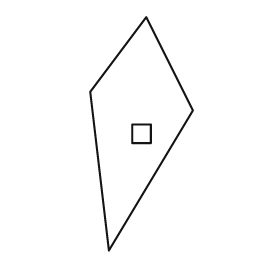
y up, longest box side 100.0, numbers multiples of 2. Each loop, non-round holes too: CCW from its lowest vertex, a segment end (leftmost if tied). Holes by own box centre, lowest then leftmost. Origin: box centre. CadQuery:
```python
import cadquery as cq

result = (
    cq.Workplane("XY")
    .moveTo(-14.0, -50.0)
    .lineTo(22.0, 10.0)
    .lineTo(2.0, 50.0)
    .lineTo(-22.0, 18.0)
    .close()
    .moveTo(-4.0, -4.0)
    .lineTo(4.0, -4.0)
    .lineTo(4.0, 4.0)
    .lineTo(-4.0, 4.0)
    .close()
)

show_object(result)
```